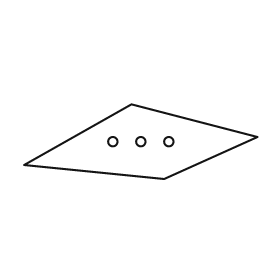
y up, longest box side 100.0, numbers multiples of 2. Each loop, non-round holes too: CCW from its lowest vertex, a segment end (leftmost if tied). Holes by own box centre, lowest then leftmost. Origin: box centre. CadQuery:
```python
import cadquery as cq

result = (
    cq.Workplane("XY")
    .moveTo(10.0, -16.0)
    .lineTo(50.0, 2.0)
    .lineTo(-4.0, 16.0)
    .lineTo(-50.0, -10.0)
    .close()
    .moveTo(-12.0, 0.0)
    .circle(2.0)
    .moveTo(0.0, 0.0)
    .circle(2.0)
    .moveTo(12.0, 0.0)
    .circle(2.0)
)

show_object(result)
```